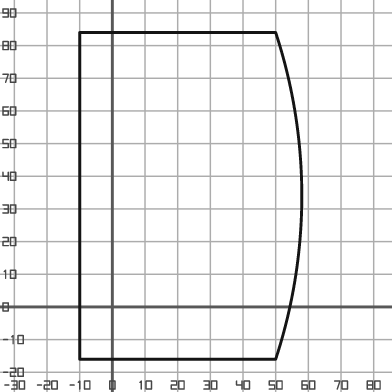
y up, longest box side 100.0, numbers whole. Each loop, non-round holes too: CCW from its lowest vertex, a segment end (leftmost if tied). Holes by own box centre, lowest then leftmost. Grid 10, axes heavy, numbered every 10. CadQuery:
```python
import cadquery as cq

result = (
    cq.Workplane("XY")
    .moveTo(-10.0, -16.0)
    .lineTo(50.0, -16.0)
    .threePointArc((58.0, 34.0), (50.0, 84.0))
    .lineTo(-10.0, 84.0)
    .close()
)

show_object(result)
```